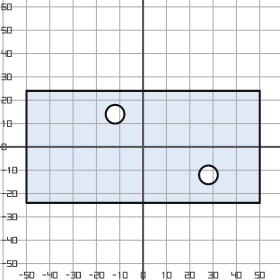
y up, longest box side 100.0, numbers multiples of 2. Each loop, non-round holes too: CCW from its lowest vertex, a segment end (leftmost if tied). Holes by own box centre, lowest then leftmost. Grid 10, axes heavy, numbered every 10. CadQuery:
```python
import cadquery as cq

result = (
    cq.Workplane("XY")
    .moveTo(-50.0, -24.0)
    .lineTo(50.0, -24.0)
    .lineTo(50.0, 24.0)
    .lineTo(-50.0, 24.0)
    .close()
    .moveTo(28.0, -12.0)
    .circle(4.0)
    .moveTo(-12.0, 14.0)
    .circle(4.0)
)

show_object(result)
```